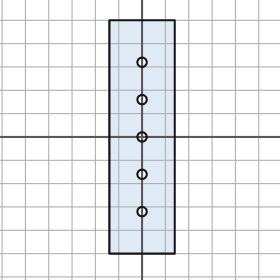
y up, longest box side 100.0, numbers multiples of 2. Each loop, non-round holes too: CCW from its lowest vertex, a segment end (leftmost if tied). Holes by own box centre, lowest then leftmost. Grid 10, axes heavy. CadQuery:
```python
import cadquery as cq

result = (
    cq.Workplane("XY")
    .moveTo(-14.0, -50.0)
    .lineTo(14.0, -50.0)
    .lineTo(14.0, 50.0)
    .lineTo(-14.0, 50.0)
    .close()
    .moveTo(0.0, -32.0)
    .circle(2.0)
    .moveTo(0.0, -16.0)
    .circle(2.0)
    .moveTo(0.0, 0.0)
    .circle(2.0)
    .moveTo(0.0, 16.0)
    .circle(2.0)
    .moveTo(0.0, 32.0)
    .circle(2.0)
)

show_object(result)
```